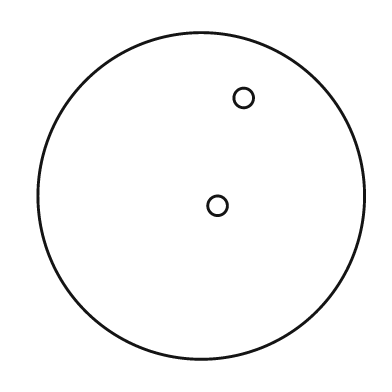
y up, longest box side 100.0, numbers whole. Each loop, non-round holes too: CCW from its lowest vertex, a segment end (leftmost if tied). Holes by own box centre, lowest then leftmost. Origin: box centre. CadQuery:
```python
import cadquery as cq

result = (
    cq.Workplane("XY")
    .moveTo(0.0, 0.0)
    .circle(50.0)
    .moveTo(5.0, -3.0)
    .circle(3.0)
    .moveTo(13.0, 30.0)
    .circle(3.0)
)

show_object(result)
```